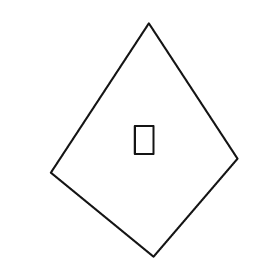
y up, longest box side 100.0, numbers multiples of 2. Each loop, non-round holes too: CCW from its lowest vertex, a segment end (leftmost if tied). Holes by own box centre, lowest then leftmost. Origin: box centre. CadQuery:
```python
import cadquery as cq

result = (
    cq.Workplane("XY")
    .moveTo(4.0, -50.0)
    .lineTo(40.0, -8.0)
    .lineTo(2.0, 50.0)
    .lineTo(-40.0, -14.0)
    .close()
    .moveTo(-4.0, -6.0)
    .lineTo(4.0, -6.0)
    .lineTo(4.0, 6.0)
    .lineTo(-4.0, 6.0)
    .close()
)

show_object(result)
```